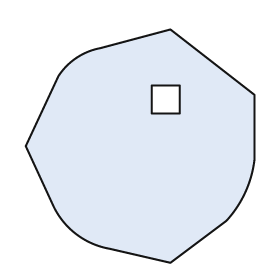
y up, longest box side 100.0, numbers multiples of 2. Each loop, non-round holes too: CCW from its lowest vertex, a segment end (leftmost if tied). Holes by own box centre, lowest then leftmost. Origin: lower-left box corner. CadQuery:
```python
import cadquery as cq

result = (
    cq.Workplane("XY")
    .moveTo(62.0, 0.0)
    .lineTo(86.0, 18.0)
    .threePointArc((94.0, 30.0), (98.0, 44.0))
    .lineTo(98.0, 72.0)
    .lineTo(62.0, 100.0)
    .lineTo(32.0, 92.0)
    .threePointArc((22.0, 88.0), (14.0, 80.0))
    .lineTo(0.0, 50.0)
    .lineTo(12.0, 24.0)
    .threePointArc((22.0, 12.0), (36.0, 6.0))
    .close()
    .moveTo(54.0, 64.0)
    .lineTo(66.0, 64.0)
    .lineTo(66.0, 76.0)
    .lineTo(54.0, 76.0)
    .close()
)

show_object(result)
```